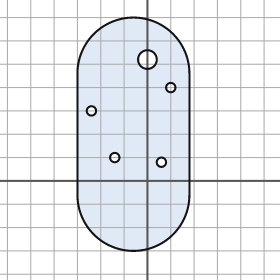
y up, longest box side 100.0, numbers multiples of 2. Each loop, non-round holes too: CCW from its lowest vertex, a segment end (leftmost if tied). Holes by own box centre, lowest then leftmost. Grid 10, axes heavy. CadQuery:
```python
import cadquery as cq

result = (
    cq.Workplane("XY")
    .moveTo(-30.0, -6.0)
    .threePointArc((-6.0, -30.0), (18.0, -6.0))
    .lineTo(18.0, 46.0)
    .threePointArc((-6.0, 70.0), (-30.0, 46.0))
    .close()
    .moveTo(6.0, 8.0)
    .circle(2.0)
    .moveTo(-14.0, 10.0)
    .circle(2.0)
    .moveTo(-24.0, 30.0)
    .circle(2.0)
    .moveTo(10.0, 40.0)
    .circle(2.0)
    .moveTo(0.0, 52.0)
    .circle(4.0)
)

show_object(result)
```